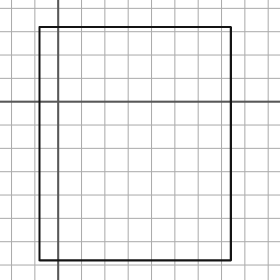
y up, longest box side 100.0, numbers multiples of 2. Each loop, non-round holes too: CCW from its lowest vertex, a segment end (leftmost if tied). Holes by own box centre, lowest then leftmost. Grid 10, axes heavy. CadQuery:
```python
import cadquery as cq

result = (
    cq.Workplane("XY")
    .moveTo(-8.0, -68.0)
    .lineTo(74.0, -68.0)
    .lineTo(74.0, 32.0)
    .lineTo(-8.0, 32.0)
    .close()
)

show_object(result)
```